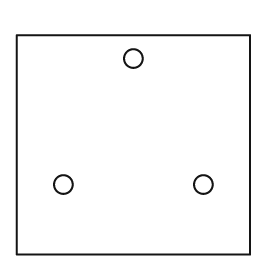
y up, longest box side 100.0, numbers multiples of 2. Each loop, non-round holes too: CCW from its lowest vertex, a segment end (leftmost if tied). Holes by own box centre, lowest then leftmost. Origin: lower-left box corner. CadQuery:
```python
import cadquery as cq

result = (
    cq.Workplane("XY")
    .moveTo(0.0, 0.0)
    .lineTo(100.0, 0.0)
    .lineTo(100.0, 94.0)
    .lineTo(0.0, 94.0)
    .close()
    .moveTo(20.0, 30.0)
    .circle(4.0)
    .moveTo(80.0, 30.0)
    .circle(4.0)
    .moveTo(50.0, 84.0)
    .circle(4.0)
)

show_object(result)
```